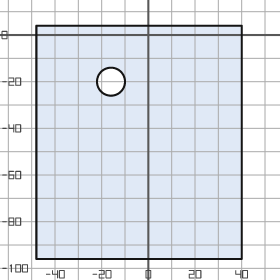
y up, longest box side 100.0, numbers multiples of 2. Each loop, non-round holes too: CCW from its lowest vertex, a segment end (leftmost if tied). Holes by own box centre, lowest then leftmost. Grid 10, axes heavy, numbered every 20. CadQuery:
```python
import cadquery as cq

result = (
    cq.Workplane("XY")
    .moveTo(-48.0, -96.0)
    .lineTo(40.0, -96.0)
    .lineTo(40.0, 4.0)
    .lineTo(-48.0, 4.0)
    .close()
    .moveTo(-16.0, -20.0)
    .circle(6.0)
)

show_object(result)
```